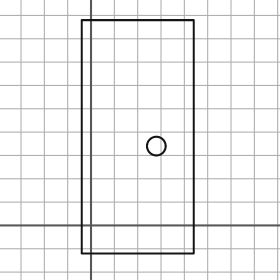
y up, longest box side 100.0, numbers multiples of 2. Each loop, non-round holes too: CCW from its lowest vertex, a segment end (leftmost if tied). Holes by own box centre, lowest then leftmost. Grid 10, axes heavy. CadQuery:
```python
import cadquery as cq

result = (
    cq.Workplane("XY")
    .moveTo(-4.0, -12.0)
    .lineTo(44.0, -12.0)
    .lineTo(44.0, 88.0)
    .lineTo(-4.0, 88.0)
    .close()
    .moveTo(28.0, 34.0)
    .circle(4.0)
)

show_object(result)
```